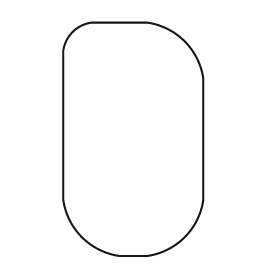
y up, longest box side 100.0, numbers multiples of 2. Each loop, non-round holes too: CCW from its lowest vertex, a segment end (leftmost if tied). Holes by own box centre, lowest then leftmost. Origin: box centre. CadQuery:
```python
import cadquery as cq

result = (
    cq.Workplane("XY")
    .moveTo(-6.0, -50.0)
    .lineTo(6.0, -50.0)
    .threePointArc((22.0, -42.0), (30.0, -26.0))
    .lineTo(30.0, 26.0)
    .threePointArc((22.0, 42.0), (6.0, 50.0))
    .lineTo(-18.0, 50.0)
    .threePointArc((-26.0, 46.0), (-30.0, 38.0))
    .lineTo(-30.0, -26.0)
    .threePointArc((-22.0, -42.0), (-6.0, -50.0))
    .close()
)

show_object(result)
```